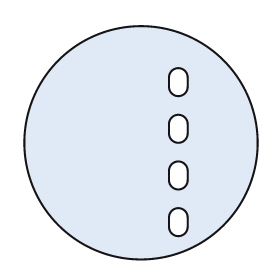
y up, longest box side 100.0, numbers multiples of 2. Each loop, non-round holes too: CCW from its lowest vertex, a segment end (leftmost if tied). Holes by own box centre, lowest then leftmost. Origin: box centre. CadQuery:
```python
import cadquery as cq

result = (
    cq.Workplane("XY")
    .moveTo(0.0, 0.0)
    .circle(50.0)
    .moveTo(12.0, -36.0)
    .threePointArc((16.0, -40.0), (20.0, -36.0))
    .lineTo(20.0, -32.0)
    .threePointArc((16.0, -28.0), (12.0, -32.0))
    .close()
    .moveTo(12.0, -16.0)
    .threePointArc((16.0, -20.0), (20.0, -16.0))
    .lineTo(20.0, -12.0)
    .threePointArc((16.0, -8.0), (12.0, -12.0))
    .close()
    .moveTo(12.0, 4.0)
    .threePointArc((16.0, 0.0), (20.0, 4.0))
    .lineTo(20.0, 8.0)
    .threePointArc((16.0, 12.0), (12.0, 8.0))
    .close()
    .moveTo(12.0, 24.0)
    .threePointArc((16.0, 20.0), (20.0, 24.0))
    .lineTo(20.0, 28.0)
    .threePointArc((16.0, 32.0), (12.0, 28.0))
    .close()
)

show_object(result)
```